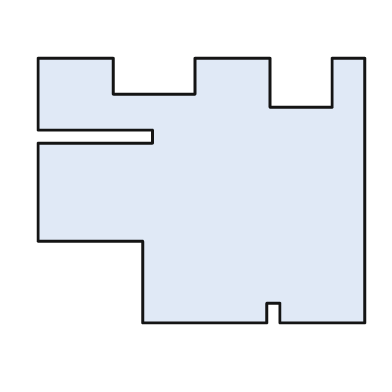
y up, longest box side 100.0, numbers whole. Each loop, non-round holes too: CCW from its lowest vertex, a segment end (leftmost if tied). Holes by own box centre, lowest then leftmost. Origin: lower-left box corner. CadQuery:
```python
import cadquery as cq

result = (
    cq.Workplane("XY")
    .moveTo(32.0, 0.0)
    .lineTo(70.0, 0.0)
    .lineTo(70.0, 6.0)
    .lineTo(74.0, 6.0)
    .lineTo(74.0, 0.0)
    .lineTo(100.0, 0.0)
    .lineTo(100.0, 81.0)
    .lineTo(90.0, 81.0)
    .lineTo(90.0, 66.0)
    .lineTo(71.0, 66.0)
    .lineTo(71.0, 81.0)
    .lineTo(48.0, 81.0)
    .lineTo(48.0, 70.0)
    .lineTo(23.0, 70.0)
    .lineTo(23.0, 81.0)
    .lineTo(0.0, 81.0)
    .lineTo(0.0, 59.0)
    .lineTo(35.0, 59.0)
    .lineTo(35.0, 55.0)
    .lineTo(0.0, 55.0)
    .lineTo(0.0, 25.0)
    .lineTo(32.0, 25.0)
    .close()
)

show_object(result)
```